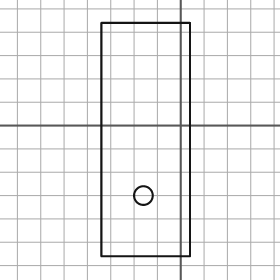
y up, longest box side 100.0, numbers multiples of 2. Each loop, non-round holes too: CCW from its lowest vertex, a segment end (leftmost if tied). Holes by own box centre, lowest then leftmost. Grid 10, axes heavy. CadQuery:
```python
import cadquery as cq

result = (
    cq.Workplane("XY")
    .moveTo(-34.0, -56.0)
    .lineTo(4.0, -56.0)
    .lineTo(4.0, 44.0)
    .lineTo(-34.0, 44.0)
    .close()
    .moveTo(-16.0, -30.0)
    .circle(4.0)
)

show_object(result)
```